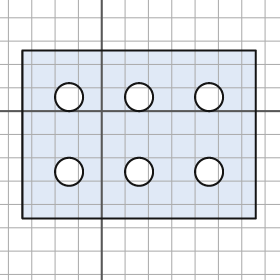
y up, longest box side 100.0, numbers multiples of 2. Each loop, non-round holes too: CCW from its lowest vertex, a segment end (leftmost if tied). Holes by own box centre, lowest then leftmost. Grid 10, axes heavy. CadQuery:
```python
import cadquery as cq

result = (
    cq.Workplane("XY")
    .moveTo(-34.0, -46.0)
    .lineTo(66.0, -46.0)
    .lineTo(66.0, 26.0)
    .lineTo(-34.0, 26.0)
    .close()
    .moveTo(-14.0, -26.0)
    .circle(6.0)
    .moveTo(16.0, -26.0)
    .circle(6.0)
    .moveTo(46.0, -26.0)
    .circle(6.0)
    .moveTo(-14.0, 6.0)
    .circle(6.0)
    .moveTo(16.0, 6.0)
    .circle(6.0)
    .moveTo(46.0, 6.0)
    .circle(6.0)
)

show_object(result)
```